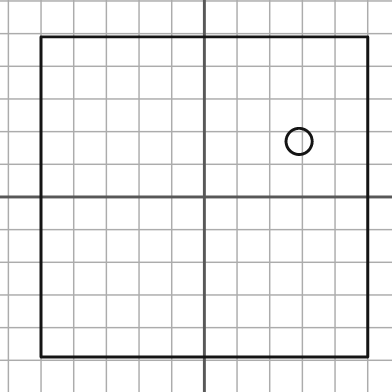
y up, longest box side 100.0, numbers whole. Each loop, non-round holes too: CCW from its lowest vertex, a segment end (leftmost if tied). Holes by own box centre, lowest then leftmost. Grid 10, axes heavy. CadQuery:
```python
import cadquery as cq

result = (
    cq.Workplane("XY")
    .moveTo(-50.0, -49.0)
    .lineTo(50.0, -49.0)
    .lineTo(50.0, 49.0)
    .lineTo(-50.0, 49.0)
    .close()
    .moveTo(29.0, 17.0)
    .circle(4.0)
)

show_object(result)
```